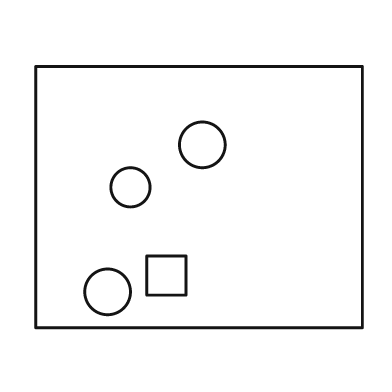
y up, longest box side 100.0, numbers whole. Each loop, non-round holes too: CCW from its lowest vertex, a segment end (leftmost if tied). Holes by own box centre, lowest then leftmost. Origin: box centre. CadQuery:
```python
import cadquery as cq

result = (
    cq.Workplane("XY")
    .moveTo(-50.0, -40.0)
    .lineTo(50.0, -40.0)
    .lineTo(50.0, 40.0)
    .lineTo(-50.0, 40.0)
    .close()
    .moveTo(-28.0, -29.0)
    .circle(7.0)
    .moveTo(-16.0, -30.0)
    .lineTo(-4.0, -30.0)
    .lineTo(-4.0, -18.0)
    .lineTo(-16.0, -18.0)
    .close()
    .moveTo(-21.0, 3.0)
    .circle(6.0)
    .moveTo(1.0, 16.0)
    .circle(7.0)
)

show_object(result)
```